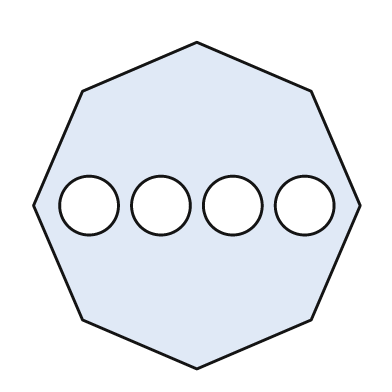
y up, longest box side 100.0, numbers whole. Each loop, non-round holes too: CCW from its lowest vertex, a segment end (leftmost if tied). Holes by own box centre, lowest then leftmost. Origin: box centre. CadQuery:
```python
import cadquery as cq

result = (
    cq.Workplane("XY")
    .moveTo(0.0, -50.0)
    .lineTo(35.0, -35.0)
    .lineTo(50.0, 0.0)
    .lineTo(35.0, 35.0)
    .lineTo(0.0, 50.0)
    .lineTo(-35.0, 35.0)
    .lineTo(-50.0, 0.0)
    .lineTo(-35.0, -35.0)
    .close()
    .moveTo(-33.0, 0.0)
    .circle(9.0)
    .moveTo(-11.0, 0.0)
    .circle(9.0)
    .moveTo(11.0, 0.0)
    .circle(9.0)
    .moveTo(33.0, 0.0)
    .circle(9.0)
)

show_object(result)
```